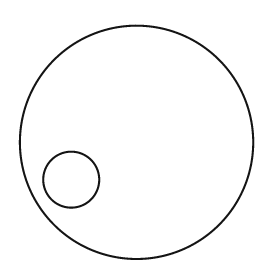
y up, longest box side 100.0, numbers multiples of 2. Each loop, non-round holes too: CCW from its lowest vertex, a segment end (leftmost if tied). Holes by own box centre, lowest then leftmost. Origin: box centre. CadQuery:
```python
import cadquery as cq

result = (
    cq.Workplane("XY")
    .moveTo(0.0, 0.0)
    .circle(50.0)
    .moveTo(-28.0, -16.0)
    .circle(12.0)
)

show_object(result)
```